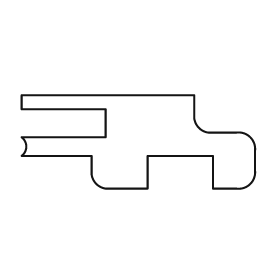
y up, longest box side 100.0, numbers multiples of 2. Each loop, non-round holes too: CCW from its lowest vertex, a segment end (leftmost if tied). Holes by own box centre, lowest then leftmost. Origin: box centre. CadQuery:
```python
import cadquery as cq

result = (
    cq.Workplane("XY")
    .moveTo(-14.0, -20.0)
    .lineTo(4.0, -20.0)
    .lineTo(4.0, -6.0)
    .lineTo(32.0, -6.0)
    .lineTo(32.0, -20.0)
    .lineTo(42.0, -20.0)
    .threePointArc((48.0, -18.0), (50.0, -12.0))
    .lineTo(50.0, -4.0)
    .threePointArc((48.0, 2.0), (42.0, 4.0))
    .lineTo(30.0, 4.0)
    .threePointArc((26.0, 6.0), (24.0, 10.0))
    .lineTo(24.0, 20.0)
    .lineTo(-50.0, 20.0)
    .lineTo(-50.0, 14.0)
    .lineTo(-14.0, 14.0)
    .lineTo(-14.0, 2.0)
    .lineTo(-50.0, 2.0)
    .threePointArc((-48.0, -2.0), (-50.0, -6.0))
    .lineTo(-20.0, -6.0)
    .lineTo(-20.0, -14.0)
    .threePointArc((-18.0, -18.0), (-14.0, -20.0))
    .close()
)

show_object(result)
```